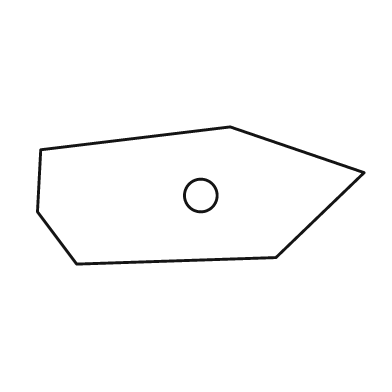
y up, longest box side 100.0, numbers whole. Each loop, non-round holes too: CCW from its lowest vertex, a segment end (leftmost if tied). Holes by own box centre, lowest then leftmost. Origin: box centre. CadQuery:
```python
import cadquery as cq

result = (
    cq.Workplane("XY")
    .moveTo(-38.0, -21.0)
    .lineTo(23.0, -19.0)
    .lineTo(50.0, 7.0)
    .lineTo(9.0, 21.0)
    .lineTo(-49.0, 14.0)
    .lineTo(-50.0, -5.0)
    .close()
    .moveTo(0.0, 0.0)
    .circle(5.0)
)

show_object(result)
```